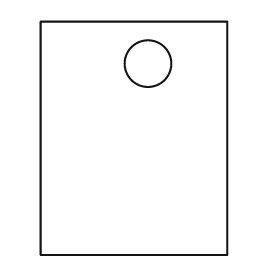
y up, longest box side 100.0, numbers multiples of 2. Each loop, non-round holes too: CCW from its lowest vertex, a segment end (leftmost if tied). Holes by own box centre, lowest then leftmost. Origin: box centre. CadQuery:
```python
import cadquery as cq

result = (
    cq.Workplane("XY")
    .moveTo(-40.0, -50.0)
    .lineTo(40.0, -50.0)
    .lineTo(40.0, 50.0)
    .lineTo(-40.0, 50.0)
    .close()
    .moveTo(6.0, 32.0)
    .circle(10.0)
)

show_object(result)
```